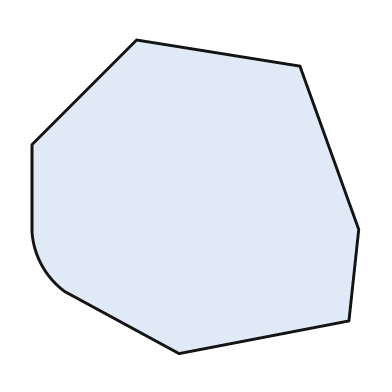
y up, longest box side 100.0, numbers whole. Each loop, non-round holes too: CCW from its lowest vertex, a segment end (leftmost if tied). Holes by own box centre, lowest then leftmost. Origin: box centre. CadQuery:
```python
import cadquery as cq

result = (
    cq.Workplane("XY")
    .moveTo(-5.0, -48.0)
    .lineTo(47.0, -38.0)
    .lineTo(50.0, -10.0)
    .lineTo(32.0, 40.0)
    .lineTo(-18.0, 48.0)
    .lineTo(-50.0, 16.0)
    .lineTo(-50.0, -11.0)
    .threePointArc((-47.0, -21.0), (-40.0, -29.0))
    .close()
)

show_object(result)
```